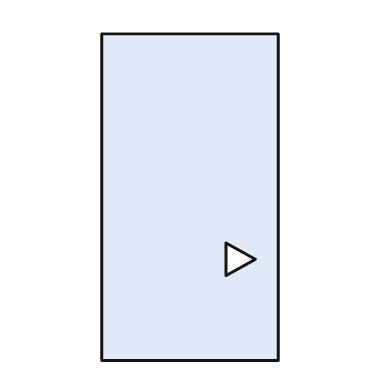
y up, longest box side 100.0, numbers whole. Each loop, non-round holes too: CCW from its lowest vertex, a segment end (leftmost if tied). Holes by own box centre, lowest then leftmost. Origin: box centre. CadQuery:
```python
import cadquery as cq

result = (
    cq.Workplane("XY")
    .moveTo(-27.0, -50.0)
    .lineTo(27.0, -50.0)
    .lineTo(27.0, 50.0)
    .lineTo(-27.0, 50.0)
    .close()
    .moveTo(11.0, -24.0)
    .lineTo(20.0, -19.0)
    .lineTo(11.0, -14.0)
    .close()
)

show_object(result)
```